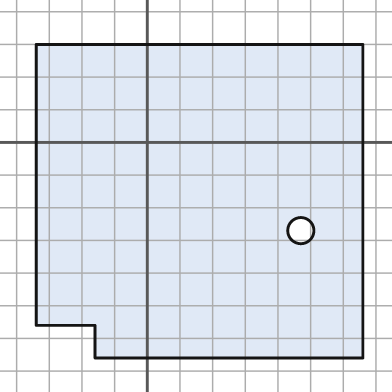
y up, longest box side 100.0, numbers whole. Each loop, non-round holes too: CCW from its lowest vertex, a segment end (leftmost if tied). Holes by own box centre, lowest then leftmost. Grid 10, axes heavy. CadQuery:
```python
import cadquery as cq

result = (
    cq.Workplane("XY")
    .moveTo(-16.0, -66.0)
    .lineTo(66.0, -66.0)
    .lineTo(66.0, 30.0)
    .lineTo(-34.0, 30.0)
    .lineTo(-34.0, -56.0)
    .lineTo(-16.0, -56.0)
    .close()
    .moveTo(47.0, -27.0)
    .circle(4.0)
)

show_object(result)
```